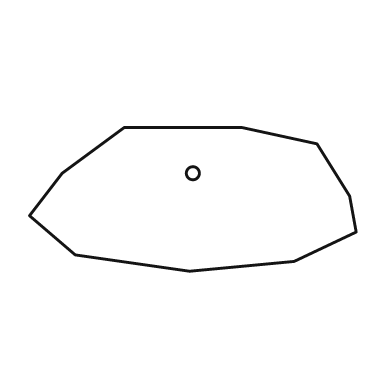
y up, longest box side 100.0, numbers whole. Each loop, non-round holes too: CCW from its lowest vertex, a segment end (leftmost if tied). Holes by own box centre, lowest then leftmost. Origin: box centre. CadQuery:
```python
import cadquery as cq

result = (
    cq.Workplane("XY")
    .moveTo(-1.0, -22.0)
    .lineTo(31.0, -19.0)
    .lineTo(50.0, -10.0)
    .lineTo(48.0, 1.0)
    .lineTo(38.0, 17.0)
    .lineTo(15.0, 22.0)
    .lineTo(-21.0, 22.0)
    .lineTo(-40.0, 8.0)
    .lineTo(-50.0, -5.0)
    .lineTo(-36.0, -17.0)
    .close()
    .moveTo(0.0, 8.0)
    .circle(2.0)
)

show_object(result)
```